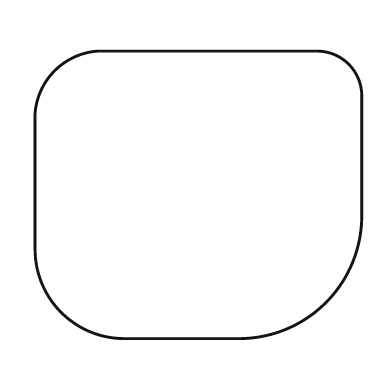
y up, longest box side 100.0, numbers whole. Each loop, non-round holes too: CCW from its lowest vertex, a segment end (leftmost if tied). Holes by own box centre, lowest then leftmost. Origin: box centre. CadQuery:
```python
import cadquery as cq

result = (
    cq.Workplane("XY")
    .moveTo(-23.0, -44.0)
    .lineTo(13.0, -44.0)
    .threePointArc((39.0, -33.0), (50.0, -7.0))
    .lineTo(50.0, 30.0)
    .threePointArc((46.0, 40.0), (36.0, 44.0))
    .lineTo(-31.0, 44.0)
    .threePointArc((-44.0, 38.0), (-50.0, 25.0))
    .lineTo(-50.0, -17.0)
    .threePointArc((-42.0, -36.0), (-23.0, -44.0))
    .close()
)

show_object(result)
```